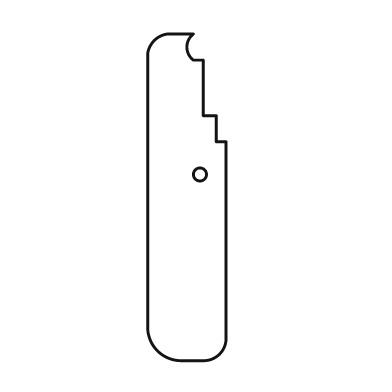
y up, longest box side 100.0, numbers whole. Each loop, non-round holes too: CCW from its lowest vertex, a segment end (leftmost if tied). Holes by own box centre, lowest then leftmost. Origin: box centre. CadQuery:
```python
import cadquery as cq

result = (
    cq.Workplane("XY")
    .moveTo(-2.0, -50.0)
    .lineTo(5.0, -50.0)
    .threePointArc((10.0, -48.0), (12.0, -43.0))
    .lineTo(12.0, 17.0)
    .lineTo(9.0, 17.0)
    .lineTo(9.0, 25.0)
    .lineTo(5.0, 25.0)
    .lineTo(5.0, 42.0)
    .lineTo(2.0, 42.0)
    .threePointArc((0.0, 46.0), (2.0, 50.0))
    .lineTo(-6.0, 50.0)
    .threePointArc((-10.0, 48.0), (-12.0, 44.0))
    .lineTo(-12.0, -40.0)
    .threePointArc((-9.0, -47.0), (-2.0, -50.0))
    .close()
    .moveTo(4.0, 7.0)
    .circle(2.0)
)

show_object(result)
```